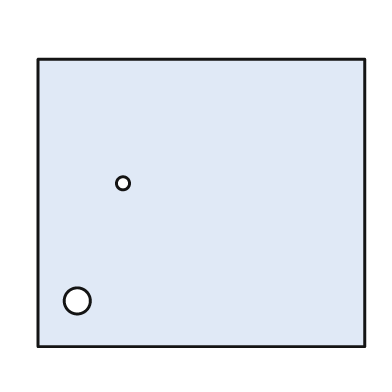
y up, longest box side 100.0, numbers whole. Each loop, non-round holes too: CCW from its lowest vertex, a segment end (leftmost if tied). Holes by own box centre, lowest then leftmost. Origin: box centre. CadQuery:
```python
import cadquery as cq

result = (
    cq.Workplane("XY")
    .moveTo(-50.0, -44.0)
    .lineTo(50.0, -44.0)
    .lineTo(50.0, 44.0)
    .lineTo(-50.0, 44.0)
    .close()
    .moveTo(-38.0, -30.0)
    .circle(4.0)
    .moveTo(-24.0, 6.0)
    .circle(2.0)
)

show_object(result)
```